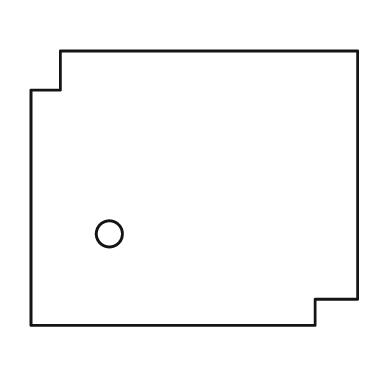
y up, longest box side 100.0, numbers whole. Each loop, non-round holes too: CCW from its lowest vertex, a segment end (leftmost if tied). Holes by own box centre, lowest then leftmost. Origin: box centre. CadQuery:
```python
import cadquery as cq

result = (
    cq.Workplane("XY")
    .moveTo(-50.0, -42.0)
    .lineTo(37.0, -42.0)
    .lineTo(37.0, -34.0)
    .lineTo(50.0, -34.0)
    .lineTo(50.0, 42.0)
    .lineTo(-41.0, 42.0)
    .lineTo(-41.0, 30.0)
    .lineTo(-50.0, 30.0)
    .close()
    .moveTo(-26.0, -14.0)
    .circle(4.0)
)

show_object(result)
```